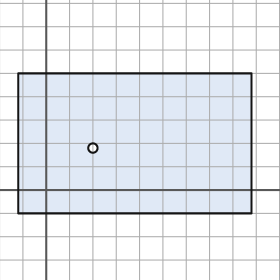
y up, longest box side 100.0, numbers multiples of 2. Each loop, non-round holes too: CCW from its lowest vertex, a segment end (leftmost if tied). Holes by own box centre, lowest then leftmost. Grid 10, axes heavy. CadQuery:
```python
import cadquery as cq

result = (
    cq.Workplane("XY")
    .moveTo(-12.0, -10.0)
    .lineTo(88.0, -10.0)
    .lineTo(88.0, 50.0)
    .lineTo(-12.0, 50.0)
    .close()
    .moveTo(20.0, 18.0)
    .circle(2.0)
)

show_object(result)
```